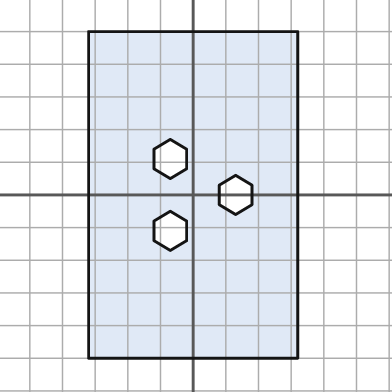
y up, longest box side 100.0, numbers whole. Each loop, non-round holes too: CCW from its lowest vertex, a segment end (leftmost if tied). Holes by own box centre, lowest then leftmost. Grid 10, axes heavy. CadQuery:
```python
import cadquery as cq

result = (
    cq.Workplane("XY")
    .moveTo(-32.0, -50.0)
    .lineTo(32.0, -50.0)
    .lineTo(32.0, 50.0)
    .lineTo(-32.0, 50.0)
    .close()
    .moveTo(-7.0, -17.0)
    .lineTo(-2.0, -14.0)
    .lineTo(-2.0, -8.0)
    .lineTo(-7.0, -5.0)
    .lineTo(-12.0, -8.0)
    .lineTo(-12.0, -14.0)
    .close()
    .moveTo(13.0, -6.0)
    .lineTo(18.0, -3.0)
    .lineTo(18.0, 3.0)
    .lineTo(13.0, 6.0)
    .lineTo(8.0, 3.0)
    .lineTo(8.0, -3.0)
    .close()
    .moveTo(-7.0, 5.0)
    .lineTo(-2.0, 8.0)
    .lineTo(-2.0, 14.0)
    .lineTo(-7.0, 17.0)
    .lineTo(-12.0, 14.0)
    .lineTo(-12.0, 8.0)
    .close()
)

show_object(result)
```